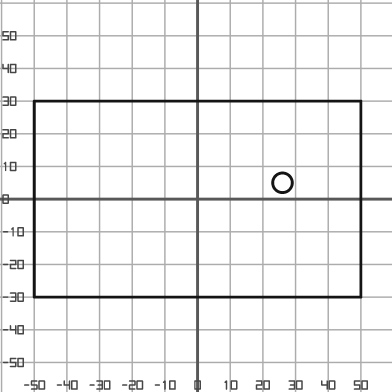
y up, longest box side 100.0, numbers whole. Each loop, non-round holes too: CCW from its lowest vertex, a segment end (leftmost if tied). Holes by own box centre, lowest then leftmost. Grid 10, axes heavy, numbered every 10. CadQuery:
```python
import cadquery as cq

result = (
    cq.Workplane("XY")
    .moveTo(-50.0, -30.0)
    .lineTo(50.0, -30.0)
    .lineTo(50.0, 30.0)
    .lineTo(-50.0, 30.0)
    .close()
    .moveTo(26.0, 5.0)
    .circle(3.0)
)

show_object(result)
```